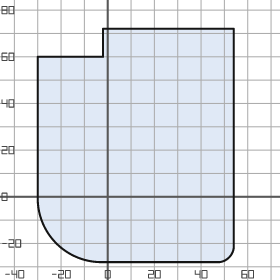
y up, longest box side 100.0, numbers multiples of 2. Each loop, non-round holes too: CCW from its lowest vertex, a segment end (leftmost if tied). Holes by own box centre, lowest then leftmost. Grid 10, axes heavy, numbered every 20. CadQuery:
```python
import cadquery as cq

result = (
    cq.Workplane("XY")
    .moveTo(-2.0, -28.0)
    .lineTo(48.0, -28.0)
    .threePointArc((52.0, -26.0), (54.0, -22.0))
    .lineTo(54.0, 72.0)
    .lineTo(-2.0, 72.0)
    .lineTo(-2.0, 60.0)
    .lineTo(-30.0, 60.0)
    .lineTo(-30.0, 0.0)
    .threePointArc((-22.0, -20.0), (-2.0, -28.0))
    .close()
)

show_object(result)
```